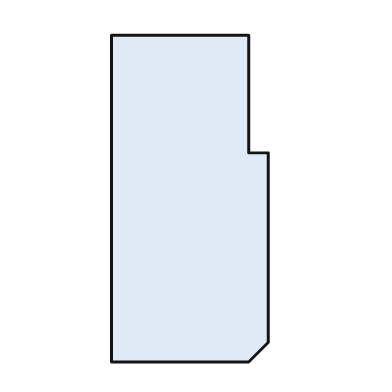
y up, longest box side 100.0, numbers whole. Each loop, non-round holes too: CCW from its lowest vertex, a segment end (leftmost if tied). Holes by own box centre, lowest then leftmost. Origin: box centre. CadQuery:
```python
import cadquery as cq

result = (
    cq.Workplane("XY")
    .moveTo(-24.0, -50.0)
    .lineTo(18.0, -50.0)
    .lineTo(24.0, -44.0)
    .lineTo(24.0, 14.0)
    .lineTo(18.0, 14.0)
    .lineTo(18.0, 50.0)
    .lineTo(-24.0, 50.0)
    .close()
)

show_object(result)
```